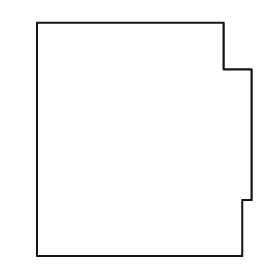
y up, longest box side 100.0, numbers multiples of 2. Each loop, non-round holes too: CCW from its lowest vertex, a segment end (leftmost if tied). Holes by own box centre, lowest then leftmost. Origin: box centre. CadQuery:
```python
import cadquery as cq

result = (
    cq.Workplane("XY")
    .moveTo(-46.0, -50.0)
    .lineTo(42.0, -50.0)
    .lineTo(42.0, -26.0)
    .lineTo(46.0, -26.0)
    .lineTo(46.0, 30.0)
    .lineTo(34.0, 30.0)
    .lineTo(34.0, 50.0)
    .lineTo(-46.0, 50.0)
    .close()
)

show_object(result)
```